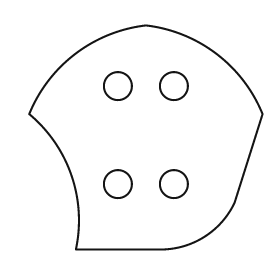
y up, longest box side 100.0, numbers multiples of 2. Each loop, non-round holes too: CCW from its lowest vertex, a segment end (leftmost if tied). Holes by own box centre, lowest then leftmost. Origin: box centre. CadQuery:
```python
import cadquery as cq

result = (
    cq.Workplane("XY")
    .moveTo(-30.0, -48.0)
    .lineTo(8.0, -48.0)
    .threePointArc((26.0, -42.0), (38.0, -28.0))
    .lineTo(50.0, 10.0)
    .threePointArc((30.0, 36.0), (0.0, 48.0))
    .threePointArc((-30.0, 36.0), (-50.0, 10.0))
    .threePointArc((-32.0, -16.0), (-30.0, -48.0))
    .close()
    .moveTo(-12.0, -20.0)
    .circle(6.0)
    .moveTo(12.0, -20.0)
    .circle(6.0)
    .moveTo(-12.0, 22.0)
    .circle(6.0)
    .moveTo(12.0, 22.0)
    .circle(6.0)
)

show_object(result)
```